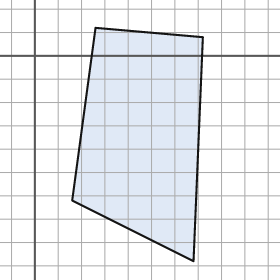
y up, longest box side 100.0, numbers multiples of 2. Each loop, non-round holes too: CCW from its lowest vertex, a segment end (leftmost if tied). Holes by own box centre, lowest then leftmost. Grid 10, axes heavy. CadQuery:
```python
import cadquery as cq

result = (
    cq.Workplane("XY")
    .moveTo(68.0, -88.0)
    .lineTo(72.0, 8.0)
    .lineTo(26.0, 12.0)
    .lineTo(16.0, -62.0)
    .close()
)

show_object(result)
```